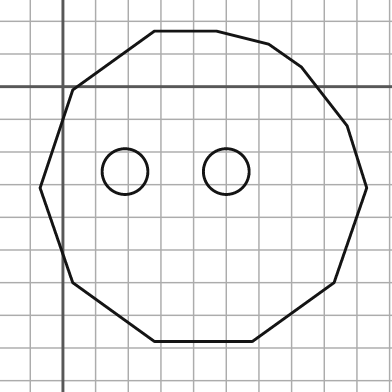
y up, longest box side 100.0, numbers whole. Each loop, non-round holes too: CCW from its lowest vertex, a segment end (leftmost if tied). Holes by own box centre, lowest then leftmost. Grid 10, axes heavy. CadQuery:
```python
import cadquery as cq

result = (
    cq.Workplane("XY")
    .moveTo(28.0, -78.0)
    .lineTo(58.0, -78.0)
    .lineTo(83.0, -60.0)
    .lineTo(93.0, -31.0)
    .lineTo(87.0, -12.0)
    .lineTo(73.0, 6.0)
    .lineTo(63.0, 13.0)
    .lineTo(47.0, 17.0)
    .lineTo(28.0, 17.0)
    .lineTo(3.0, -1.0)
    .lineTo(-7.0, -31.0)
    .lineTo(3.0, -60.0)
    .close()
    .moveTo(19.0, -26.0)
    .circle(7.0)
    .moveTo(50.0, -26.0)
    .circle(7.0)
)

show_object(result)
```